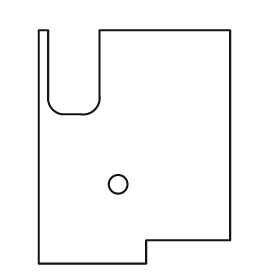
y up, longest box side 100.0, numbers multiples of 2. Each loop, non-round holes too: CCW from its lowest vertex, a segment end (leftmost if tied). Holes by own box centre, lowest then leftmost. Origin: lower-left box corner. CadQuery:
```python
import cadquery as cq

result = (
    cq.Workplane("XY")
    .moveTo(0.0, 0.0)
    .lineTo(46.0, 0.0)
    .lineTo(46.0, 10.0)
    .lineTo(82.0, 10.0)
    .lineTo(82.0, 100.0)
    .lineTo(26.0, 100.0)
    .lineTo(26.0, 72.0)
    .threePointArc((24.0, 66.0), (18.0, 64.0))
    .lineTo(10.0, 64.0)
    .threePointArc((6.0, 66.0), (4.0, 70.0))
    .lineTo(4.0, 100.0)
    .lineTo(0.0, 100.0)
    .close()
    .moveTo(34.0, 34.0)
    .circle(4.0)
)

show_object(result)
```